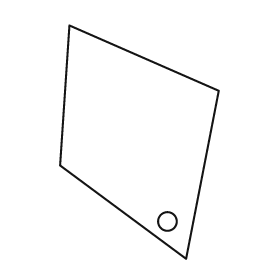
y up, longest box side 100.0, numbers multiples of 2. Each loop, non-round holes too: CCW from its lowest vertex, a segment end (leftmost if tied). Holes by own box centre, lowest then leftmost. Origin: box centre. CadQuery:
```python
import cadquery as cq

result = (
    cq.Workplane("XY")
    .moveTo(20.0, -50.0)
    .lineTo(34.0, 22.0)
    .lineTo(-30.0, 50.0)
    .lineTo(-34.0, -10.0)
    .close()
    .moveTo(12.0, -34.0)
    .circle(4.0)
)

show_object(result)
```